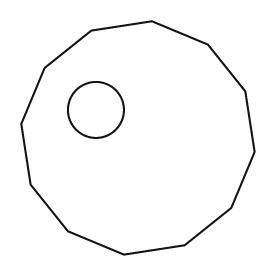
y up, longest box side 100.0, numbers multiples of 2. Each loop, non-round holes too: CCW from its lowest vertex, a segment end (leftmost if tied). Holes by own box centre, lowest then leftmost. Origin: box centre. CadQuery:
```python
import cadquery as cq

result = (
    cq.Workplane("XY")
    .moveTo(-6.0, -50.0)
    .lineTo(20.0, -46.0)
    .lineTo(40.0, -30.0)
    .lineTo(50.0, -6.0)
    .lineTo(46.0, 20.0)
    .lineTo(30.0, 40.0)
    .lineTo(6.0, 50.0)
    .lineTo(-20.0, 46.0)
    .lineTo(-40.0, 30.0)
    .lineTo(-50.0, 6.0)
    .lineTo(-46.0, -20.0)
    .lineTo(-30.0, -40.0)
    .close()
    .moveTo(-18.0, 12.0)
    .circle(12.0)
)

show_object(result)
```